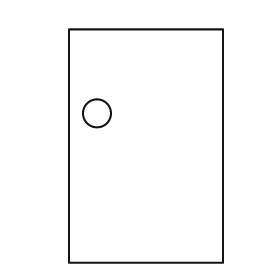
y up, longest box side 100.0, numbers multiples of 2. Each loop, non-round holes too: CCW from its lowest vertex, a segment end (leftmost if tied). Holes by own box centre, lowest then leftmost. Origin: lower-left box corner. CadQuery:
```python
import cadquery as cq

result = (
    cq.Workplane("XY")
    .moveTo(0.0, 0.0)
    .lineTo(66.0, 0.0)
    .lineTo(66.0, 100.0)
    .lineTo(0.0, 100.0)
    .close()
    .moveTo(12.0, 64.0)
    .circle(6.0)
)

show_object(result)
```